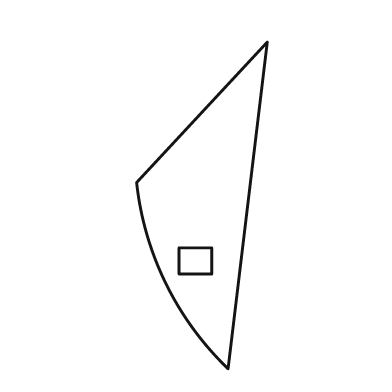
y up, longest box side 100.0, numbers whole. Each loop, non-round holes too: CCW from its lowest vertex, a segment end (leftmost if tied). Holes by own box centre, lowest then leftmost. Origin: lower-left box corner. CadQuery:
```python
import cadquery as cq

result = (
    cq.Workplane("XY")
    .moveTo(28.0, 0.0)
    .lineTo(40.0, 100.0)
    .lineTo(0.0, 57.0)
    .threePointArc((9.0, 26.0), (28.0, 0.0))
    .close()
    .moveTo(13.0, 29.0)
    .lineTo(23.0, 29.0)
    .lineTo(23.0, 37.0)
    .lineTo(13.0, 37.0)
    .close()
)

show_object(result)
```